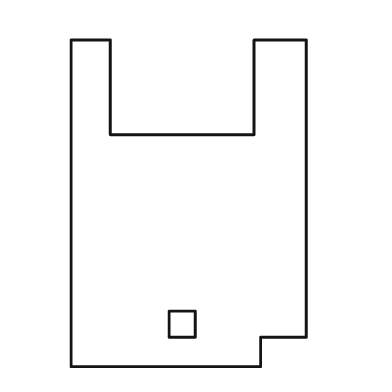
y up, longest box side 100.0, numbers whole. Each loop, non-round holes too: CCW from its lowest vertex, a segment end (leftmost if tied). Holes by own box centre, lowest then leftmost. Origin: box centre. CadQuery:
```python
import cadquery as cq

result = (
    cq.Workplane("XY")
    .moveTo(-36.0, -50.0)
    .lineTo(22.0, -50.0)
    .lineTo(22.0, -41.0)
    .lineTo(36.0, -41.0)
    .lineTo(36.0, 50.0)
    .lineTo(20.0, 50.0)
    .lineTo(20.0, 21.0)
    .lineTo(-24.0, 21.0)
    .lineTo(-24.0, 50.0)
    .lineTo(-36.0, 50.0)
    .close()
    .moveTo(-6.0, -41.0)
    .lineTo(2.0, -41.0)
    .lineTo(2.0, -33.0)
    .lineTo(-6.0, -33.0)
    .close()
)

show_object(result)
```